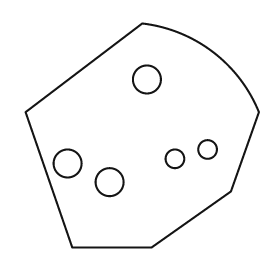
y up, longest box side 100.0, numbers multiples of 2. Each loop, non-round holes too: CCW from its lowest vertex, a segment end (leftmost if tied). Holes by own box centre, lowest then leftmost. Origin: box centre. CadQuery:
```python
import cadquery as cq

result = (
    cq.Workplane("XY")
    .moveTo(-30.0, -48.0)
    .lineTo(4.0, -48.0)
    .lineTo(38.0, -24.0)
    .lineTo(50.0, 10.0)
    .threePointArc((30.0, 36.0), (0.0, 48.0))
    .lineTo(-50.0, 10.0)
    .close()
    .moveTo(-14.0, -20.0)
    .circle(6.0)
    .moveTo(-32.0, -12.0)
    .circle(6.0)
    .moveTo(14.0, -10.0)
    .circle(4.0)
    .moveTo(28.0, -6.0)
    .circle(4.0)
    .moveTo(2.0, 24.0)
    .circle(6.0)
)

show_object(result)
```